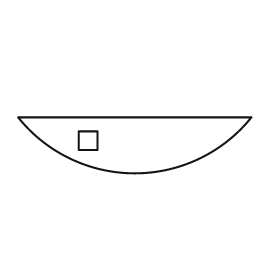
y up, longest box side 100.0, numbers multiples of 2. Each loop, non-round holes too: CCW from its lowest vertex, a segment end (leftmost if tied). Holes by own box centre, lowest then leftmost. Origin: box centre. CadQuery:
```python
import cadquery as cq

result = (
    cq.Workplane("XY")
    .moveTo(-50.0, 12.0)
    .threePointArc((0.0, -12.0), (50.0, 12.0))
    .close()
    .moveTo(-24.0, -2.0)
    .lineTo(-16.0, -2.0)
    .lineTo(-16.0, 6.0)
    .lineTo(-24.0, 6.0)
    .close()
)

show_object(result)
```